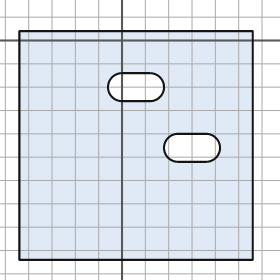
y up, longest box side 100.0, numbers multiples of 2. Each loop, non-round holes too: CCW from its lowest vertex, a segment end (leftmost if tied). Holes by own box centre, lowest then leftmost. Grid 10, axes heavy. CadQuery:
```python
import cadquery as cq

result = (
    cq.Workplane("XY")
    .moveTo(-44.0, -94.0)
    .lineTo(56.0, -94.0)
    .lineTo(56.0, 4.0)
    .lineTo(-44.0, 4.0)
    .close()
    .moveTo(24.0, -52.0)
    .lineTo(36.0, -52.0)
    .threePointArc((42.0, -46.0), (36.0, -40.0))
    .lineTo(24.0, -40.0)
    .threePointArc((18.0, -46.0), (24.0, -52.0))
    .close()
    .moveTo(0.0, -26.0)
    .lineTo(12.0, -26.0)
    .threePointArc((18.0, -20.0), (12.0, -14.0))
    .lineTo(0.0, -14.0)
    .threePointArc((-6.0, -20.0), (0.0, -26.0))
    .close()
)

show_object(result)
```